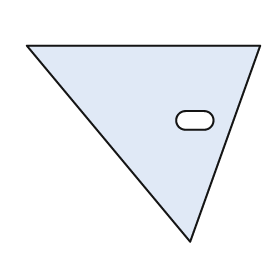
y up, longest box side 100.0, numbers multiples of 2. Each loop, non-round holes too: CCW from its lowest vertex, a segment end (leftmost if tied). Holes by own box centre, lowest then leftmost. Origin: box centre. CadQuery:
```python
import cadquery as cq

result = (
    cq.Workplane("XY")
    .moveTo(20.0, -42.0)
    .lineTo(50.0, 42.0)
    .lineTo(-50.0, 42.0)
    .close()
    .moveTo(18.0, 6.0)
    .lineTo(26.0, 6.0)
    .threePointArc((30.0, 10.0), (26.0, 14.0))
    .lineTo(18.0, 14.0)
    .threePointArc((14.0, 10.0), (18.0, 6.0))
    .close()
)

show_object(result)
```